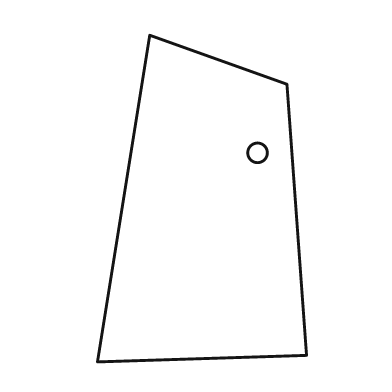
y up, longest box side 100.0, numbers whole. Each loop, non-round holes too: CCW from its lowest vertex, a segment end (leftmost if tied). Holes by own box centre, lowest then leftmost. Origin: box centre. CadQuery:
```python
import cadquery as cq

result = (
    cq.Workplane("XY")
    .moveTo(-32.0, -50.0)
    .lineTo(32.0, -48.0)
    .lineTo(26.0, 35.0)
    .lineTo(-16.0, 50.0)
    .close()
    .moveTo(17.0, 14.0)
    .circle(3.0)
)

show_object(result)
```